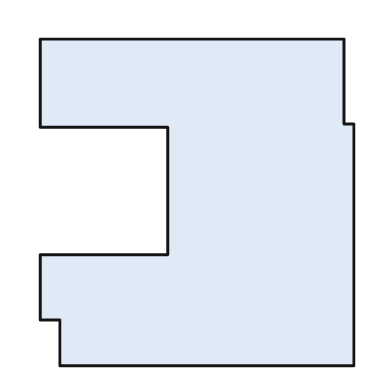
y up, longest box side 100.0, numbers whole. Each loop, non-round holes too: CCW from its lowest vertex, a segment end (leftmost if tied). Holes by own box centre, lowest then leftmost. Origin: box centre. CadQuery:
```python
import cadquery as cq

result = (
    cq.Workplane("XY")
    .moveTo(-42.0, -50.0)
    .lineTo(48.0, -50.0)
    .lineTo(48.0, 24.0)
    .lineTo(45.0, 24.0)
    .lineTo(45.0, 50.0)
    .lineTo(-48.0, 50.0)
    .lineTo(-48.0, 23.0)
    .lineTo(-9.0, 23.0)
    .lineTo(-9.0, -16.0)
    .lineTo(-48.0, -16.0)
    .lineTo(-48.0, -36.0)
    .lineTo(-42.0, -36.0)
    .close()
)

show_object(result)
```